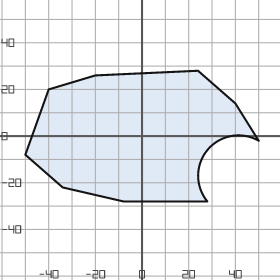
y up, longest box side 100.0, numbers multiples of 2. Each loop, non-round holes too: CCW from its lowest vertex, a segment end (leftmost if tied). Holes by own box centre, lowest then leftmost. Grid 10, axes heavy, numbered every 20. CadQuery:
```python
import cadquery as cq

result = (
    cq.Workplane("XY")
    .moveTo(-8.0, -28.0)
    .lineTo(28.0, -28.0)
    .threePointArc((28.0, -6.0), (50.0, -2.0))
    .lineTo(40.0, 14.0)
    .lineTo(24.0, 28.0)
    .lineTo(-20.0, 26.0)
    .lineTo(-40.0, 20.0)
    .lineTo(-50.0, -8.0)
    .lineTo(-34.0, -22.0)
    .close()
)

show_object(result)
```